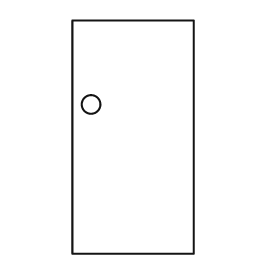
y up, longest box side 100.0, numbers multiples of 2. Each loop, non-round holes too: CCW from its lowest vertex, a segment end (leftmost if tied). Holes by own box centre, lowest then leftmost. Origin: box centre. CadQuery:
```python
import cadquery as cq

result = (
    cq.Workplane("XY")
    .moveTo(-26.0, -50.0)
    .lineTo(26.0, -50.0)
    .lineTo(26.0, 50.0)
    .lineTo(-26.0, 50.0)
    .close()
    .moveTo(-18.0, 14.0)
    .circle(4.0)
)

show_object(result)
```